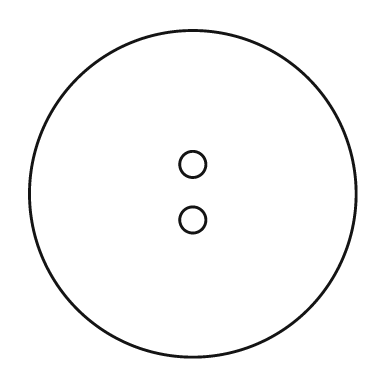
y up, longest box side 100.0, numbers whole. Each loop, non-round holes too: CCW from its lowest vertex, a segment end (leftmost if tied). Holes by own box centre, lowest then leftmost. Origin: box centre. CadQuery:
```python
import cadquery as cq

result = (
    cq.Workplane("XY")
    .moveTo(0.0, 0.0)
    .circle(50.0)
    .moveTo(0.0, -8.0)
    .circle(4.0)
    .moveTo(0.0, 9.0)
    .circle(4.0)
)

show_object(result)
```